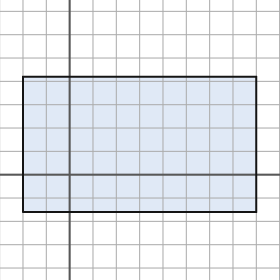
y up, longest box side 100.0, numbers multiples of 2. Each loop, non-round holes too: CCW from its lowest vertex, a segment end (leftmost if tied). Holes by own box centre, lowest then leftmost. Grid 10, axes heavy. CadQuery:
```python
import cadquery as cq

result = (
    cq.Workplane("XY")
    .moveTo(-20.0, -16.0)
    .lineTo(80.0, -16.0)
    .lineTo(80.0, 42.0)
    .lineTo(-20.0, 42.0)
    .close()
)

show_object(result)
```